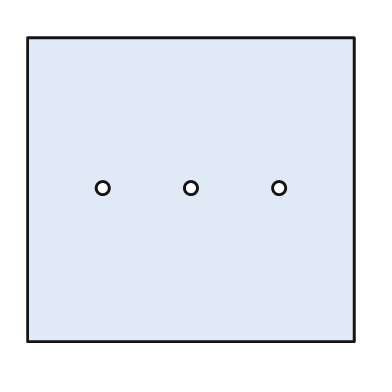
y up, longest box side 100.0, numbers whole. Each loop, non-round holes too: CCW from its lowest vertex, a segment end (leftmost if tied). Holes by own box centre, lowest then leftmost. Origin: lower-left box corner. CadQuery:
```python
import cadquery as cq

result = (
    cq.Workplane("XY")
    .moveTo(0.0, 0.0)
    .lineTo(100.0, 0.0)
    .lineTo(100.0, 93.0)
    .lineTo(0.0, 93.0)
    .close()
    .moveTo(23.0, 47.0)
    .circle(2.0)
    .moveTo(50.0, 47.0)
    .circle(2.0)
    .moveTo(77.0, 47.0)
    .circle(2.0)
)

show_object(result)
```